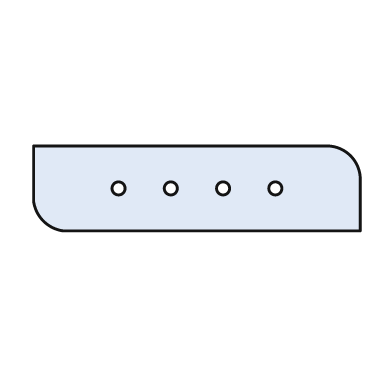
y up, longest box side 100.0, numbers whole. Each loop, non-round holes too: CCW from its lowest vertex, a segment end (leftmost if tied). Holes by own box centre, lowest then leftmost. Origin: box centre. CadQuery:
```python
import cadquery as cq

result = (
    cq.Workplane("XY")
    .moveTo(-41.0, -13.0)
    .lineTo(50.0, -13.0)
    .lineTo(50.0, 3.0)
    .threePointArc((47.0, 10.0), (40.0, 13.0))
    .lineTo(-50.0, 13.0)
    .lineTo(-50.0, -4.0)
    .threePointArc((-47.0, -10.0), (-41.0, -13.0))
    .close()
    .moveTo(-24.0, 0.0)
    .circle(2.0)
    .moveTo(-8.0, 0.0)
    .circle(2.0)
    .moveTo(8.0, 0.0)
    .circle(2.0)
    .moveTo(24.0, 0.0)
    .circle(2.0)
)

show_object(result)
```